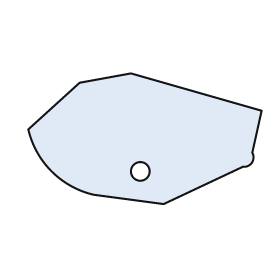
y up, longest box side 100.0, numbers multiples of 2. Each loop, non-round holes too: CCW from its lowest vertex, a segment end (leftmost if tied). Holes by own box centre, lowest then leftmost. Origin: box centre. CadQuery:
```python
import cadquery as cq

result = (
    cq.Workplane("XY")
    .moveTo(8.0, -28.0)
    .lineTo(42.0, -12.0)
    .threePointArc((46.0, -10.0), (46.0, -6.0))
    .lineTo(50.0, 12.0)
    .lineTo(-6.0, 28.0)
    .lineTo(-28.0, 24.0)
    .lineTo(-50.0, 4.0)
    .threePointArc((-40.0, -14.0), (-22.0, -24.0))
    .close()
    .moveTo(-2.0, -14.0)
    .circle(4.0)
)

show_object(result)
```